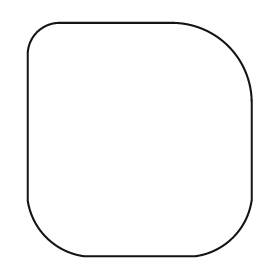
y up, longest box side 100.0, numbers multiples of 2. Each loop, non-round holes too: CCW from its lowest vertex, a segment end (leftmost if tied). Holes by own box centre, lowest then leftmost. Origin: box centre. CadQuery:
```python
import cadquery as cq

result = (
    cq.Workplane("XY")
    .moveTo(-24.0, -50.0)
    .lineTo(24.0, -50.0)
    .threePointArc((40.0, -42.0), (48.0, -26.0))
    .lineTo(48.0, 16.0)
    .threePointArc((38.0, 40.0), (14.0, 50.0))
    .lineTo(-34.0, 50.0)
    .threePointArc((-44.0, 46.0), (-48.0, 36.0))
    .lineTo(-48.0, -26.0)
    .threePointArc((-40.0, -42.0), (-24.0, -50.0))
    .close()
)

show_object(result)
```